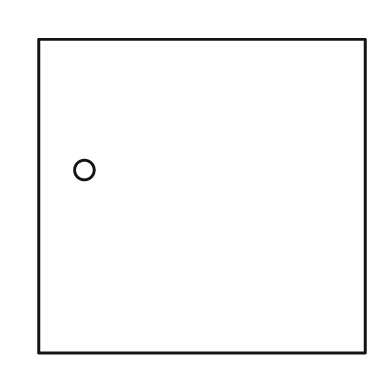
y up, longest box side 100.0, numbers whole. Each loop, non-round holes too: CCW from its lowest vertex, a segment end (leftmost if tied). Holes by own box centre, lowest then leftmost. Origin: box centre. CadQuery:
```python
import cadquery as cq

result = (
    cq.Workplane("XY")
    .moveTo(-50.0, -48.0)
    .lineTo(50.0, -48.0)
    .lineTo(50.0, 48.0)
    .lineTo(-50.0, 48.0)
    .close()
    .moveTo(-36.0, 8.0)
    .circle(3.0)
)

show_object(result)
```